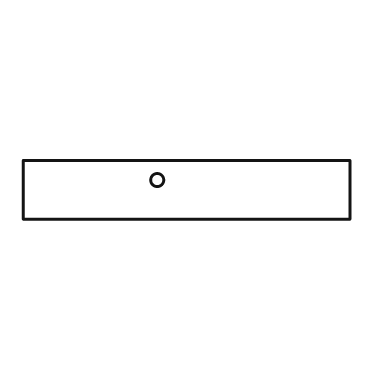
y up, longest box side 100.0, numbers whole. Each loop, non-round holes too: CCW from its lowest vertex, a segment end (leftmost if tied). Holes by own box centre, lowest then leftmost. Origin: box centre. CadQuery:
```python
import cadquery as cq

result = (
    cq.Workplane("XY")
    .moveTo(-50.0, -9.0)
    .lineTo(50.0, -9.0)
    .lineTo(50.0, 9.0)
    .lineTo(-50.0, 9.0)
    .close()
    .moveTo(-9.0, 3.0)
    .circle(2.0)
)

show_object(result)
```